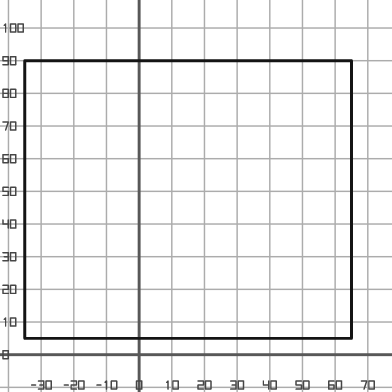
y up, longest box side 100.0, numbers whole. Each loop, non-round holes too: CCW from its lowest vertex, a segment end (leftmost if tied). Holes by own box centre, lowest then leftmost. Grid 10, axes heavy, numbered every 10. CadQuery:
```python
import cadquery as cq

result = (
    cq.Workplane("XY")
    .moveTo(-35.0, 5.0)
    .lineTo(65.0, 5.0)
    .lineTo(65.0, 90.0)
    .lineTo(-35.0, 90.0)
    .close()
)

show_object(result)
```